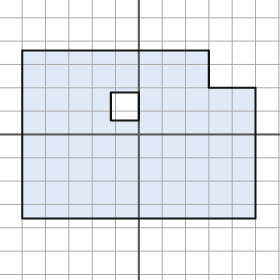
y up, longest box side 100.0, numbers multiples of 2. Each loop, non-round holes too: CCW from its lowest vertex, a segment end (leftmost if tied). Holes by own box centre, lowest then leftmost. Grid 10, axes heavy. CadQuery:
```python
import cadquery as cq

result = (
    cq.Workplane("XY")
    .moveTo(-50.0, -36.0)
    .lineTo(50.0, -36.0)
    .lineTo(50.0, 20.0)
    .lineTo(30.0, 20.0)
    .lineTo(30.0, 36.0)
    .lineTo(-50.0, 36.0)
    .close()
    .moveTo(-12.0, 6.0)
    .lineTo(0.0, 6.0)
    .lineTo(0.0, 18.0)
    .lineTo(-12.0, 18.0)
    .close()
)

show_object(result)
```